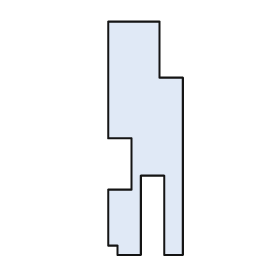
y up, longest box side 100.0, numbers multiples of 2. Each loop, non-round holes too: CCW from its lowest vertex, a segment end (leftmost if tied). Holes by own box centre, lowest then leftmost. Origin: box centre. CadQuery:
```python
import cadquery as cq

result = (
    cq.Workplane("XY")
    .moveTo(-12.0, -50.0)
    .lineTo(-2.0, -50.0)
    .lineTo(-2.0, -16.0)
    .lineTo(8.0, -16.0)
    .lineTo(8.0, -50.0)
    .lineTo(16.0, -50.0)
    .lineTo(16.0, 26.0)
    .lineTo(6.0, 26.0)
    .lineTo(6.0, 50.0)
    .lineTo(-16.0, 50.0)
    .lineTo(-16.0, 0.0)
    .lineTo(-6.0, 0.0)
    .lineTo(-6.0, -22.0)
    .lineTo(-16.0, -22.0)
    .lineTo(-16.0, -46.0)
    .lineTo(-12.0, -46.0)
    .close()
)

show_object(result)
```